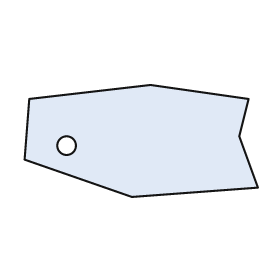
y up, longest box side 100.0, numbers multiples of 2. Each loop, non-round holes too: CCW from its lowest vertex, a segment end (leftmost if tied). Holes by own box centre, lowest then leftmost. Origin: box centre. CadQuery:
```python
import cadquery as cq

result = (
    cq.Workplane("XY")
    .moveTo(-4.0, -24.0)
    .lineTo(50.0, -20.0)
    .lineTo(42.0, 2.0)
    .lineTo(46.0, 18.0)
    .lineTo(4.0, 24.0)
    .lineTo(-48.0, 18.0)
    .lineTo(-50.0, -8.0)
    .close()
    .moveTo(-32.0, -2.0)
    .circle(4.0)
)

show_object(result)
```